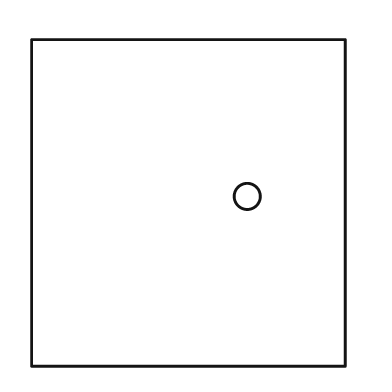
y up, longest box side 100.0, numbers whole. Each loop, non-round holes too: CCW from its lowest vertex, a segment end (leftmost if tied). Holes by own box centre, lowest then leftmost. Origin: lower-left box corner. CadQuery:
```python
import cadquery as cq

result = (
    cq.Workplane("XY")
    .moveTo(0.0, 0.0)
    .lineTo(96.0, 0.0)
    .lineTo(96.0, 100.0)
    .lineTo(0.0, 100.0)
    .close()
    .moveTo(66.0, 52.0)
    .circle(4.0)
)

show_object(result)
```